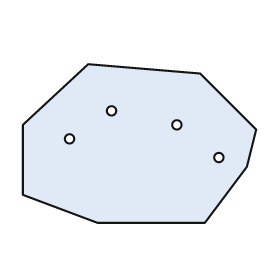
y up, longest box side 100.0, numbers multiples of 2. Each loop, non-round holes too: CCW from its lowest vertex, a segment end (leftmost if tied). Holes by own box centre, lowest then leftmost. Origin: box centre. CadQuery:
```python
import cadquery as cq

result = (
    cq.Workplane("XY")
    .moveTo(-18.0, -34.0)
    .lineTo(28.0, -34.0)
    .lineTo(46.0, -10.0)
    .lineTo(50.0, 6.0)
    .lineTo(26.0, 30.0)
    .lineTo(-22.0, 34.0)
    .lineTo(-50.0, 8.0)
    .lineTo(-50.0, -22.0)
    .close()
    .moveTo(34.0, -6.0)
    .circle(2.0)
    .moveTo(-30.0, 2.0)
    .circle(2.0)
    .moveTo(16.0, 8.0)
    .circle(2.0)
    .moveTo(-12.0, 14.0)
    .circle(2.0)
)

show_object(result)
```